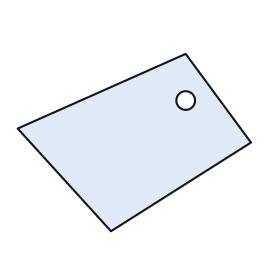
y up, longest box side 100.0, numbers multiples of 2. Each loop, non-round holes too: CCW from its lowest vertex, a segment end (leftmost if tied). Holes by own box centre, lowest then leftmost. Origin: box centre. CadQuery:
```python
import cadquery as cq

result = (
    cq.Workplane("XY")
    .moveTo(-10.0, -38.0)
    .lineTo(50.0, 0.0)
    .lineTo(22.0, 38.0)
    .lineTo(-50.0, 6.0)
    .close()
    .moveTo(22.0, 18.0)
    .circle(4.0)
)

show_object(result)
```